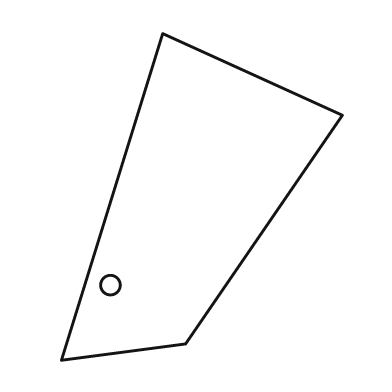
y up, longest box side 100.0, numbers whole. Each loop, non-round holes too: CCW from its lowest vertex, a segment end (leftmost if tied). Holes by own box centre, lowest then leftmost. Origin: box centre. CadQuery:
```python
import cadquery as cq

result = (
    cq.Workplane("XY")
    .moveTo(-43.0, -50.0)
    .lineTo(-5.0, -45.0)
    .lineTo(43.0, 25.0)
    .lineTo(-12.0, 50.0)
    .close()
    .moveTo(-28.0, -27.0)
    .circle(3.0)
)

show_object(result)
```